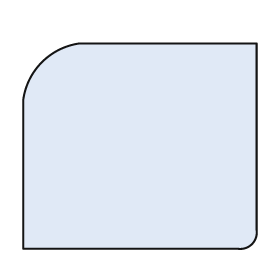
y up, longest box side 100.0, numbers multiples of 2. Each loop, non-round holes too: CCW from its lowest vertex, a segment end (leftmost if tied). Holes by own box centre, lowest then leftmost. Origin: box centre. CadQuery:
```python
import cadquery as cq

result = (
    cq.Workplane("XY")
    .moveTo(-50.0, -44.0)
    .lineTo(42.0, -44.0)
    .threePointArc((48.0, -42.0), (50.0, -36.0))
    .lineTo(50.0, 44.0)
    .lineTo(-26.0, 44.0)
    .threePointArc((-42.0, 36.0), (-50.0, 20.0))
    .close()
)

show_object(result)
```